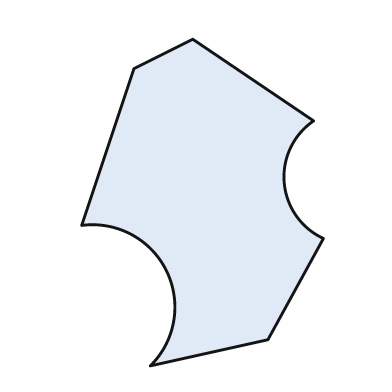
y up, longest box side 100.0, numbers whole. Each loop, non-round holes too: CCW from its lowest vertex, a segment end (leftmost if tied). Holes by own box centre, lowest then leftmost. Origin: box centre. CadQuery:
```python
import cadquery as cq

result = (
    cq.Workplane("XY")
    .moveTo(-16.0, -50.0)
    .lineTo(20.0, -42.0)
    .lineTo(37.0, -11.0)
    .threePointArc((25.0, 6.0), (34.0, 25.0))
    .lineTo(-3.0, 50.0)
    .lineTo(-21.0, 41.0)
    .lineTo(-37.0, -7.0)
    .threePointArc((-11.0, -21.0), (-16.0, -50.0))
    .close()
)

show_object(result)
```